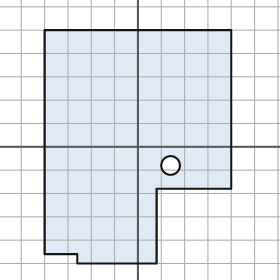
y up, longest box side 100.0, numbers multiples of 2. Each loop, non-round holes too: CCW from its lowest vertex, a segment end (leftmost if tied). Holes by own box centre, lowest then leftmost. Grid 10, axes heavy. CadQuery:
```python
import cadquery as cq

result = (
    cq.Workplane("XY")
    .moveTo(-26.0, -50.0)
    .lineTo(8.0, -50.0)
    .lineTo(8.0, -18.0)
    .lineTo(40.0, -18.0)
    .lineTo(40.0, 50.0)
    .lineTo(-40.0, 50.0)
    .lineTo(-40.0, -46.0)
    .lineTo(-26.0, -46.0)
    .close()
    .moveTo(14.0, -8.0)
    .circle(4.0)
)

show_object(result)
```